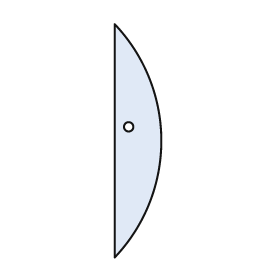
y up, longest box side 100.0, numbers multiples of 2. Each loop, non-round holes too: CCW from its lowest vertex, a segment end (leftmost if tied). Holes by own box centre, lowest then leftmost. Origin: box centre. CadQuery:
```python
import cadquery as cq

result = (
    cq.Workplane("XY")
    .moveTo(-10.0, -50.0)
    .threePointArc((10.0, 0.0), (-10.0, 50.0))
    .close()
    .moveTo(-4.0, 6.0)
    .circle(2.0)
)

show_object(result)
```